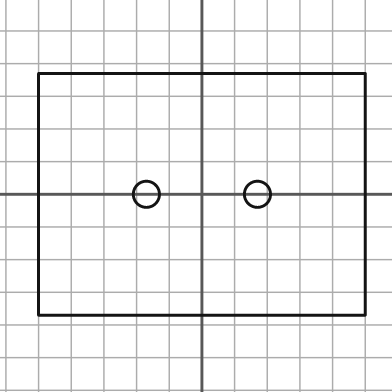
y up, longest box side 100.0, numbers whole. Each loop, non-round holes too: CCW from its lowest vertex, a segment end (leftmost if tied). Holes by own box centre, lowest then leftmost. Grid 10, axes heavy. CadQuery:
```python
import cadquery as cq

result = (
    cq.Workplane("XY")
    .moveTo(-50.0, -37.0)
    .lineTo(50.0, -37.0)
    .lineTo(50.0, 37.0)
    .lineTo(-50.0, 37.0)
    .close()
    .moveTo(-17.0, 0.0)
    .circle(4.0)
    .moveTo(17.0, 0.0)
    .circle(4.0)
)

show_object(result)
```